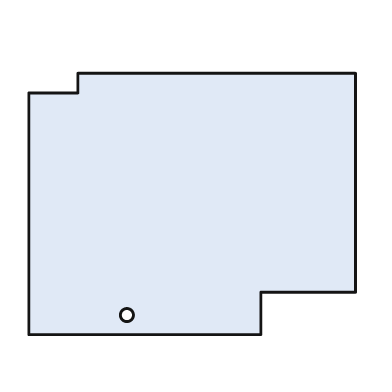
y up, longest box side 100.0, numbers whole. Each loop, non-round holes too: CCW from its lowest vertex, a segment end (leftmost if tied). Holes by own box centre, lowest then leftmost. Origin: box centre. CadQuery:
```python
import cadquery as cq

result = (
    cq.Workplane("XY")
    .moveTo(-50.0, -40.0)
    .lineTo(21.0, -40.0)
    .lineTo(21.0, -27.0)
    .lineTo(50.0, -27.0)
    .lineTo(50.0, 40.0)
    .lineTo(-35.0, 40.0)
    .lineTo(-35.0, 34.0)
    .lineTo(-50.0, 34.0)
    .close()
    .moveTo(-20.0, -34.0)
    .circle(2.0)
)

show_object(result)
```